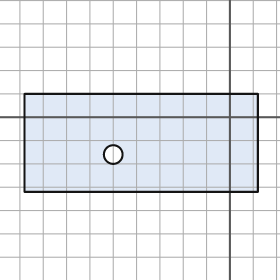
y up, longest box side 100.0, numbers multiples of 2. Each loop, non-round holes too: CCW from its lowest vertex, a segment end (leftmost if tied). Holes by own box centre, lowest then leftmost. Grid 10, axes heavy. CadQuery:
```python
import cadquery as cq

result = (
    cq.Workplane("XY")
    .moveTo(-88.0, -32.0)
    .lineTo(12.0, -32.0)
    .lineTo(12.0, 10.0)
    .lineTo(-88.0, 10.0)
    .close()
    .moveTo(-50.0, -16.0)
    .circle(4.0)
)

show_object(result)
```